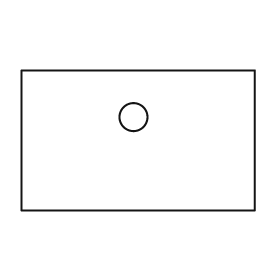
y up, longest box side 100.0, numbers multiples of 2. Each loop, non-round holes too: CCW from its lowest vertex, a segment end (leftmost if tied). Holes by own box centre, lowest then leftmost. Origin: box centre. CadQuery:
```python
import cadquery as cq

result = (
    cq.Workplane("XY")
    .moveTo(-50.0, -30.0)
    .lineTo(50.0, -30.0)
    .lineTo(50.0, 30.0)
    .lineTo(-50.0, 30.0)
    .close()
    .moveTo(-2.0, 10.0)
    .circle(6.0)
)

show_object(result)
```